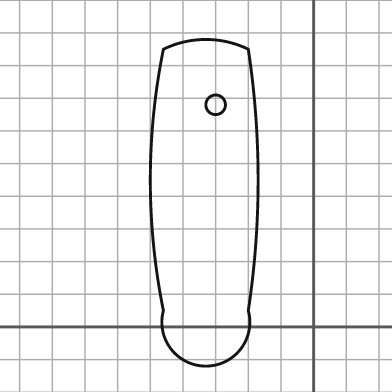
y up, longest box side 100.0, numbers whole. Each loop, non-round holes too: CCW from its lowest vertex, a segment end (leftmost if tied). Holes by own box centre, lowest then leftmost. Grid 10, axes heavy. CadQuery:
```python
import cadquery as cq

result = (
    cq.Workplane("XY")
    .moveTo(-46.0, 5.0)
    .threePointArc((-33.0, -12.0), (-20.0, 5.0))
    .threePointArc((-17.0, 45.0), (-20.0, 85.0))
    .threePointArc((-33.0, 88.0), (-46.0, 85.0))
    .threePointArc((-50.0, 45.0), (-46.0, 5.0))
    .close()
    .moveTo(-30.0, 68.0)
    .circle(3.0)
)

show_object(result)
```